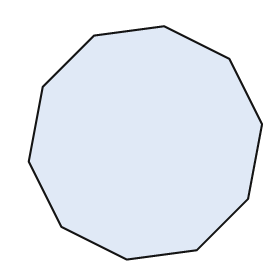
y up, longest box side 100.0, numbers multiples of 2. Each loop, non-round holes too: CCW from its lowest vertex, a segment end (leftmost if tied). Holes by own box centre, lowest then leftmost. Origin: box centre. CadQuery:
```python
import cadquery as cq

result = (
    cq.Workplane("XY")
    .moveTo(-8.0, -50.0)
    .lineTo(22.0, -46.0)
    .lineTo(44.0, -24.0)
    .lineTo(50.0, 8.0)
    .lineTo(36.0, 36.0)
    .lineTo(8.0, 50.0)
    .lineTo(-22.0, 46.0)
    .lineTo(-44.0, 24.0)
    .lineTo(-50.0, -8.0)
    .lineTo(-36.0, -36.0)
    .close()
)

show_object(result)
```